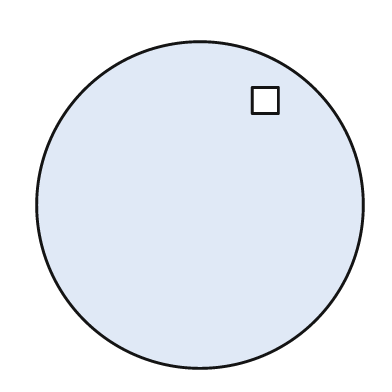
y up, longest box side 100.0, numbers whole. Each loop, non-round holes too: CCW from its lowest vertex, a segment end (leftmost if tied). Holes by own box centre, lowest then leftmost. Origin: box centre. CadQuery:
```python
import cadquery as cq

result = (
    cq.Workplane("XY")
    .moveTo(0.0, 0.0)
    .circle(50.0)
    .moveTo(16.0, 28.0)
    .lineTo(24.0, 28.0)
    .lineTo(24.0, 36.0)
    .lineTo(16.0, 36.0)
    .close()
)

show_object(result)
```